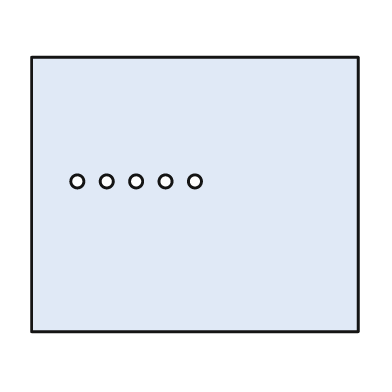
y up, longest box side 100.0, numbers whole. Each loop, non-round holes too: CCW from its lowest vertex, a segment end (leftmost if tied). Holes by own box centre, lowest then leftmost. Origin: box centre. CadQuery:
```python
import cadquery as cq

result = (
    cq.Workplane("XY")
    .moveTo(-50.0, -42.0)
    .lineTo(50.0, -42.0)
    .lineTo(50.0, 42.0)
    .lineTo(-50.0, 42.0)
    .close()
    .moveTo(-36.0, 4.0)
    .circle(2.0)
    .moveTo(-27.0, 4.0)
    .circle(2.0)
    .moveTo(-18.0, 4.0)
    .circle(2.0)
    .moveTo(-9.0, 4.0)
    .circle(2.0)
    .moveTo(0.0, 4.0)
    .circle(2.0)
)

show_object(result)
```